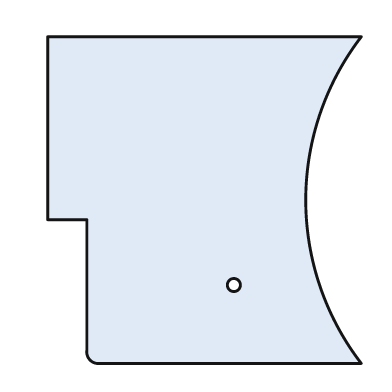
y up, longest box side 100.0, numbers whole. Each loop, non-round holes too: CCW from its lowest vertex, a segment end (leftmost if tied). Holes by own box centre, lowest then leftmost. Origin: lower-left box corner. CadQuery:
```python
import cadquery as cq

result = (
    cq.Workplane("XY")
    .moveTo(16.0, 0.0)
    .lineTo(96.0, 0.0)
    .threePointArc((79.0, 50.0), (96.0, 100.0))
    .lineTo(0.0, 100.0)
    .lineTo(0.0, 44.0)
    .lineTo(12.0, 44.0)
    .lineTo(12.0, 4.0)
    .threePointArc((13.0, 1.0), (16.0, 0.0))
    .close()
    .moveTo(57.0, 24.0)
    .circle(2.0)
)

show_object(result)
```